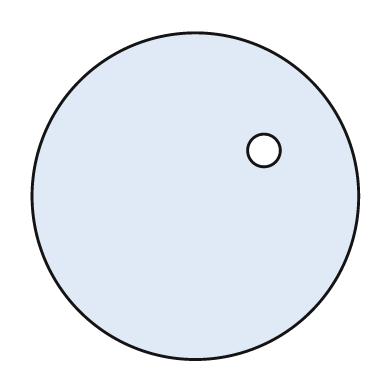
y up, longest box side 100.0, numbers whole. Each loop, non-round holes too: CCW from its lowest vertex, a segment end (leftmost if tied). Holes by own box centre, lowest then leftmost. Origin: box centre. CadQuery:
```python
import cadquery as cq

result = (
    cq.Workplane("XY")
    .moveTo(0.0, 0.0)
    .circle(50.0)
    .moveTo(21.0, 14.0)
    .circle(5.0)
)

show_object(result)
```